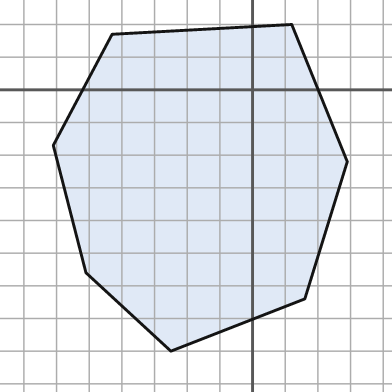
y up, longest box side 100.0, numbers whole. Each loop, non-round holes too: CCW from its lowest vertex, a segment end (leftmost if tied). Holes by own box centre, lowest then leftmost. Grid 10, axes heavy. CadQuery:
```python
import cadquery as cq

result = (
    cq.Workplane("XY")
    .moveTo(-25.0, -80.0)
    .lineTo(16.0, -64.0)
    .lineTo(29.0, -22.0)
    .lineTo(12.0, 20.0)
    .lineTo(-43.0, 17.0)
    .lineTo(-61.0, -17.0)
    .lineTo(-51.0, -56.0)
    .close()
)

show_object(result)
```